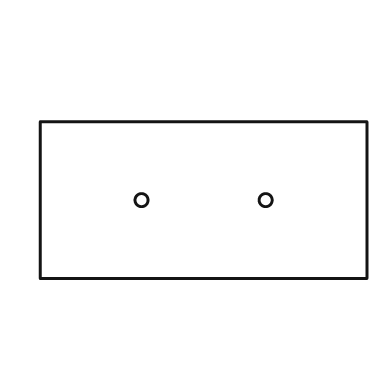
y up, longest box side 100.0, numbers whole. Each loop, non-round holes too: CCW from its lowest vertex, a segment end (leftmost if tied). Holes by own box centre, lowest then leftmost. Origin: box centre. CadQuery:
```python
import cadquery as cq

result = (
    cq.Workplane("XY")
    .moveTo(-50.0, -24.0)
    .lineTo(50.0, -24.0)
    .lineTo(50.0, 24.0)
    .lineTo(-50.0, 24.0)
    .close()
    .moveTo(-19.0, 0.0)
    .circle(2.0)
    .moveTo(19.0, 0.0)
    .circle(2.0)
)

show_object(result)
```